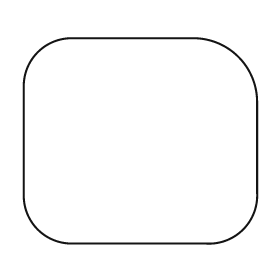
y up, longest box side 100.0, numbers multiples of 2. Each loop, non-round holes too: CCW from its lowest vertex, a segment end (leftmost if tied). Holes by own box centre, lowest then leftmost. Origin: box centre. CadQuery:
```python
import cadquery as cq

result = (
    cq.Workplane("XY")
    .moveTo(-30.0, -44.0)
    .lineTo(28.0, -44.0)
    .threePointArc((44.0, -38.0), (50.0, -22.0))
    .lineTo(50.0, 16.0)
    .threePointArc((42.0, 36.0), (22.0, 44.0))
    .lineTo(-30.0, 44.0)
    .threePointArc((-44.0, 38.0), (-50.0, 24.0))
    .lineTo(-50.0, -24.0)
    .threePointArc((-44.0, -38.0), (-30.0, -44.0))
    .close()
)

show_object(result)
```